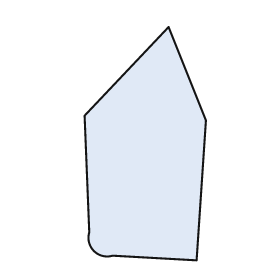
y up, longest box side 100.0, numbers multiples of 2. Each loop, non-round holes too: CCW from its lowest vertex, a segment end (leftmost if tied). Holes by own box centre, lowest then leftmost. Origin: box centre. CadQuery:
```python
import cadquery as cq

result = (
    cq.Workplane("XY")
    .moveTo(22.0, -50.0)
    .lineTo(26.0, 10.0)
    .lineTo(10.0, 50.0)
    .lineTo(-26.0, 12.0)
    .lineTo(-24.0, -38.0)
    .threePointArc((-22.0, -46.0), (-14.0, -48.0))
    .close()
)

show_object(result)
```